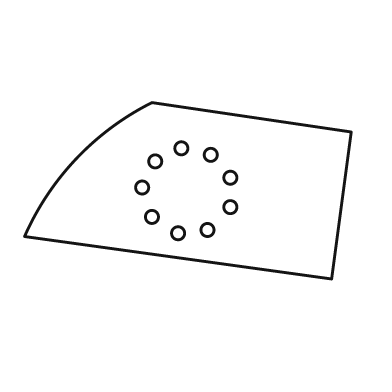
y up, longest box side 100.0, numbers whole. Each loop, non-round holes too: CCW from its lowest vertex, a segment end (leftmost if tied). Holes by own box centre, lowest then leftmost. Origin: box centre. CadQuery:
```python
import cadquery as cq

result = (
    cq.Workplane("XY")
    .moveTo(44.0, -27.0)
    .lineTo(50.0, 18.0)
    .lineTo(-11.0, 27.0)
    .threePointArc((-34.0, 10.0), (-50.0, -14.0))
    .close()
    .moveTo(-3.0, -13.0)
    .circle(2.0)
    .moveTo(6.0, -12.0)
    .circle(2.0)
    .moveTo(-11.0, -8.0)
    .circle(2.0)
    .moveTo(13.0, -5.0)
    .circle(2.0)
    .moveTo(-14.0, 1.0)
    .circle(2.0)
    .moveTo(13.0, 4.0)
    .circle(2.0)
    .moveTo(-10.0, 9.0)
    .circle(2.0)
    .moveTo(7.0, 11.0)
    .circle(2.0)
    .moveTo(-2.0, 13.0)
    .circle(2.0)
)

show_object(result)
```